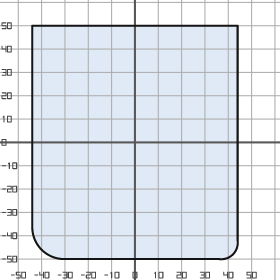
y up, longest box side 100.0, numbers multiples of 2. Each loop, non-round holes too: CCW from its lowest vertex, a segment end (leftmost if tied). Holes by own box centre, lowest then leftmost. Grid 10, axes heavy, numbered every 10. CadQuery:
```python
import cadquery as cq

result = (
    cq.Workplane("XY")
    .moveTo(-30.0, -50.0)
    .lineTo(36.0, -50.0)
    .threePointArc((42.0, -48.0), (44.0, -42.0))
    .lineTo(44.0, 50.0)
    .lineTo(-44.0, 50.0)
    .lineTo(-44.0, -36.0)
    .threePointArc((-40.0, -46.0), (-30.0, -50.0))
    .close()
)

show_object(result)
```